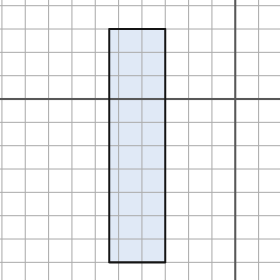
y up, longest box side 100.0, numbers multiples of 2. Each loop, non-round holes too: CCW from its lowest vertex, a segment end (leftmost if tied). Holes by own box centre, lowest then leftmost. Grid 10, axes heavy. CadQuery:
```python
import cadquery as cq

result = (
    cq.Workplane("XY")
    .moveTo(-54.0, -70.0)
    .lineTo(-30.0, -70.0)
    .lineTo(-30.0, 30.0)
    .lineTo(-54.0, 30.0)
    .close()
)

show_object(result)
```